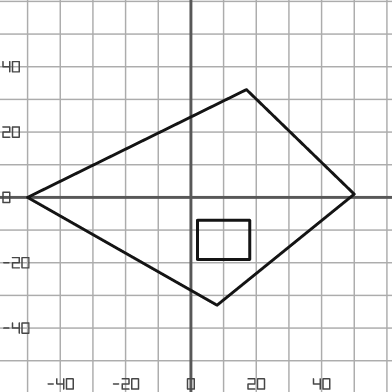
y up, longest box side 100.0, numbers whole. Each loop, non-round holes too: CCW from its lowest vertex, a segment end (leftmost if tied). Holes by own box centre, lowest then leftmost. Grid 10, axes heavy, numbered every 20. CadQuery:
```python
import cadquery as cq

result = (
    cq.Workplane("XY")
    .moveTo(8.0, -33.0)
    .lineTo(50.0, 1.0)
    .lineTo(17.0, 33.0)
    .lineTo(-50.0, 0.0)
    .close()
    .moveTo(2.0, -19.0)
    .lineTo(18.0, -19.0)
    .lineTo(18.0, -7.0)
    .lineTo(2.0, -7.0)
    .close()
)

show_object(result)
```